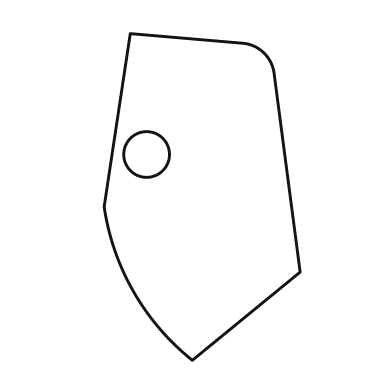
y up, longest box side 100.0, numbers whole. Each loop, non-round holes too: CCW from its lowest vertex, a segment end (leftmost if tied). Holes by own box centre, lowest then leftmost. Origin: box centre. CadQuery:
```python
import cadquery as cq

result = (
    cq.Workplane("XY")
    .moveTo(-3.0, -50.0)
    .lineTo(30.0, -23.0)
    .lineTo(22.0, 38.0)
    .threePointArc((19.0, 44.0), (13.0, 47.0))
    .lineTo(-22.0, 50.0)
    .lineTo(-30.0, -3.0)
    .threePointArc((-21.0, -29.0), (-3.0, -50.0))
    .close()
    .moveTo(-17.0, 13.0)
    .circle(7.0)
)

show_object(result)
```